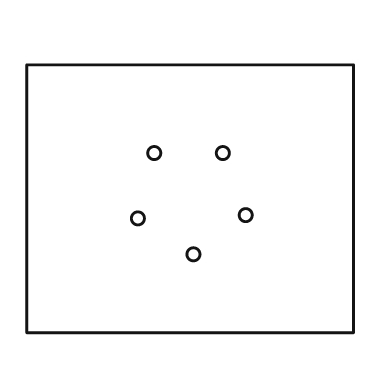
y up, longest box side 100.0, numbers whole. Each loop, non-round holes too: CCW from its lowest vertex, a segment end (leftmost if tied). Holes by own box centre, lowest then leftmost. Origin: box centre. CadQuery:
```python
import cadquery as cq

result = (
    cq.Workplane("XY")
    .moveTo(-50.0, -41.0)
    .lineTo(50.0, -41.0)
    .lineTo(50.0, 41.0)
    .lineTo(-50.0, 41.0)
    .close()
    .moveTo(1.0, -17.0)
    .circle(2.0)
    .moveTo(-16.0, -6.0)
    .circle(2.0)
    .moveTo(17.0, -5.0)
    .circle(2.0)
    .moveTo(-11.0, 14.0)
    .circle(2.0)
    .moveTo(10.0, 14.0)
    .circle(2.0)
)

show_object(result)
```